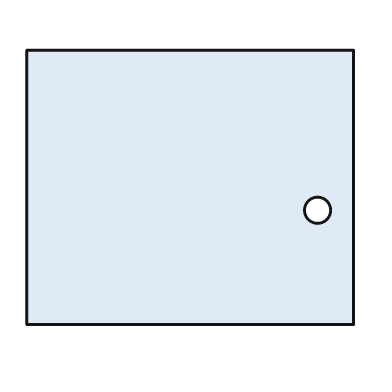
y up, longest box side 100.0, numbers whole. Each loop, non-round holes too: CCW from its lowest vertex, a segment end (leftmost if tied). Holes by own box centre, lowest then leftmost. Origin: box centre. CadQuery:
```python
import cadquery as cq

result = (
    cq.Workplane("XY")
    .moveTo(-50.0, -42.0)
    .lineTo(50.0, -42.0)
    .lineTo(50.0, 42.0)
    .lineTo(-50.0, 42.0)
    .close()
    .moveTo(39.0, -7.0)
    .circle(4.0)
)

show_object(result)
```